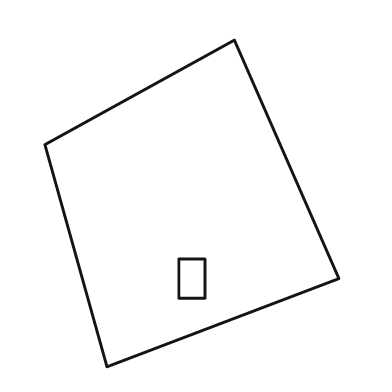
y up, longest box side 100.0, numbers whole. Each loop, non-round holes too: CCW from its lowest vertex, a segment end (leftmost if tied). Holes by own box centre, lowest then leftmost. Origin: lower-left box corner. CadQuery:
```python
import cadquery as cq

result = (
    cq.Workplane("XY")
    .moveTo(19.0, 0.0)
    .lineTo(90.0, 27.0)
    .lineTo(58.0, 100.0)
    .lineTo(0.0, 68.0)
    .close()
    .moveTo(41.0, 21.0)
    .lineTo(49.0, 21.0)
    .lineTo(49.0, 33.0)
    .lineTo(41.0, 33.0)
    .close()
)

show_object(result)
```